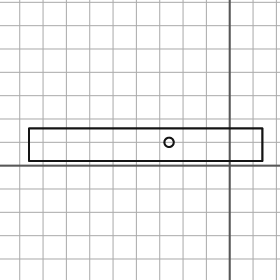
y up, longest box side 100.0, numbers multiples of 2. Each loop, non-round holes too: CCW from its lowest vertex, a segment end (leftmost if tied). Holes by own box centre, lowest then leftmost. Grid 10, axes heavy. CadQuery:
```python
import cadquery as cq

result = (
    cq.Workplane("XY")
    .moveTo(-86.0, 2.0)
    .lineTo(14.0, 2.0)
    .lineTo(14.0, 16.0)
    .lineTo(-86.0, 16.0)
    .close()
    .moveTo(-26.0, 10.0)
    .circle(2.0)
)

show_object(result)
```